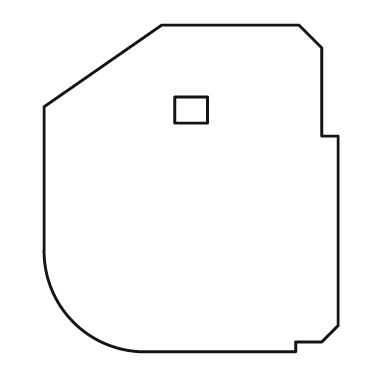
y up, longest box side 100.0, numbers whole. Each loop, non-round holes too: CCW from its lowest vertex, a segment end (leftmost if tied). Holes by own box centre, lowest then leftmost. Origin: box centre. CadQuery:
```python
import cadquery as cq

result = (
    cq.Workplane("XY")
    .moveTo(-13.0, -50.0)
    .lineTo(32.0, -50.0)
    .lineTo(32.0, -47.0)
    .lineTo(40.0, -47.0)
    .lineTo(45.0, -42.0)
    .lineTo(45.0, 16.0)
    .lineTo(40.0, 16.0)
    .lineTo(40.0, 43.0)
    .lineTo(33.0, 50.0)
    .lineTo(-9.0, 50.0)
    .lineTo(-45.0, 25.0)
    .lineTo(-45.0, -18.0)
    .threePointArc((-36.0, -41.0), (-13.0, -50.0))
    .close()
    .moveTo(-5.0, 20.0)
    .lineTo(5.0, 20.0)
    .lineTo(5.0, 28.0)
    .lineTo(-5.0, 28.0)
    .close()
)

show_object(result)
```